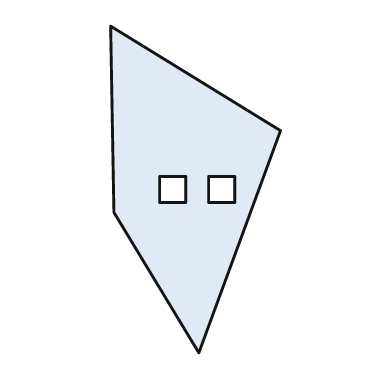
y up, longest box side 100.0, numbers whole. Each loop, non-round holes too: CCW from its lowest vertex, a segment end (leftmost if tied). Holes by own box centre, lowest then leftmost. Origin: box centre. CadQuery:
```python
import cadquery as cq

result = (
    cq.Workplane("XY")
    .moveTo(1.0, -50.0)
    .lineTo(26.0, 18.0)
    .lineTo(-26.0, 50.0)
    .lineTo(-25.0, -7.0)
    .close()
    .moveTo(-11.0, -4.0)
    .lineTo(-3.0, -4.0)
    .lineTo(-3.0, 4.0)
    .lineTo(-11.0, 4.0)
    .close()
    .moveTo(4.0, -4.0)
    .lineTo(12.0, -4.0)
    .lineTo(12.0, 4.0)
    .lineTo(4.0, 4.0)
    .close()
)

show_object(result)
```